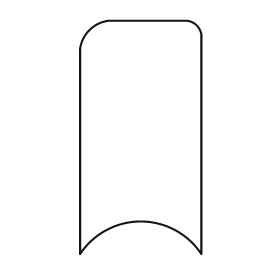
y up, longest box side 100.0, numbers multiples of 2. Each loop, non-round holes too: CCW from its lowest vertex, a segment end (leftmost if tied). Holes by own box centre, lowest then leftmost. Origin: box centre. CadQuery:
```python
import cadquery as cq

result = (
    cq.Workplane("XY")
    .moveTo(-26.0, -50.0)
    .threePointArc((0.0, -36.0), (26.0, -50.0))
    .lineTo(26.0, 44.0)
    .threePointArc((24.0, 48.0), (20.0, 50.0))
    .lineTo(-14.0, 50.0)
    .threePointArc((-22.0, 46.0), (-26.0, 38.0))
    .close()
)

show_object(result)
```